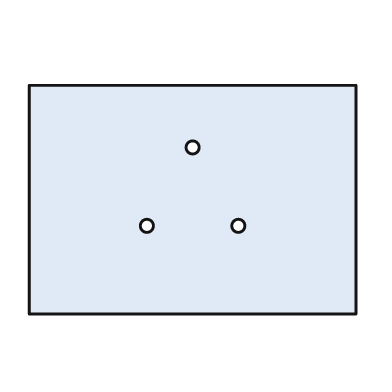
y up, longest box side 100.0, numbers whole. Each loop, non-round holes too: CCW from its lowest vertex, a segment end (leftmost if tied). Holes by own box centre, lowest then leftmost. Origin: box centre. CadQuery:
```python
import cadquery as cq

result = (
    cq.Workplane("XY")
    .moveTo(-50.0, -35.0)
    .lineTo(50.0, -35.0)
    .lineTo(50.0, 35.0)
    .lineTo(-50.0, 35.0)
    .close()
    .moveTo(-14.0, -8.0)
    .circle(2.0)
    .moveTo(14.0, -8.0)
    .circle(2.0)
    .moveTo(0.0, 16.0)
    .circle(2.0)
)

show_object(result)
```